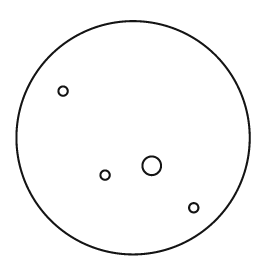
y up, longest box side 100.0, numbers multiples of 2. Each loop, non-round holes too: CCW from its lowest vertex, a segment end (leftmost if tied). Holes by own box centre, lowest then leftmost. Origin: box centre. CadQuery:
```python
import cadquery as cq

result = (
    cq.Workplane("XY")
    .moveTo(0.0, 0.0)
    .circle(50.0)
    .moveTo(26.0, -30.0)
    .circle(2.0)
    .moveTo(-12.0, -16.0)
    .circle(2.0)
    .moveTo(8.0, -12.0)
    .circle(4.0)
    .moveTo(-30.0, 20.0)
    .circle(2.0)
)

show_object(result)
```